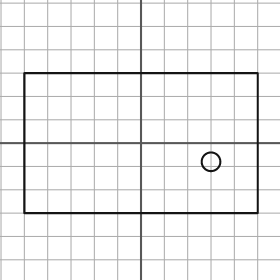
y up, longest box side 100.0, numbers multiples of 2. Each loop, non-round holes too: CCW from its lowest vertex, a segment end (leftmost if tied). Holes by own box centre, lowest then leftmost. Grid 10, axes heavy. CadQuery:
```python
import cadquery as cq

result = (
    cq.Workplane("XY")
    .moveTo(-50.0, -30.0)
    .lineTo(50.0, -30.0)
    .lineTo(50.0, 30.0)
    .lineTo(-50.0, 30.0)
    .close()
    .moveTo(30.0, -8.0)
    .circle(4.0)
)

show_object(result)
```